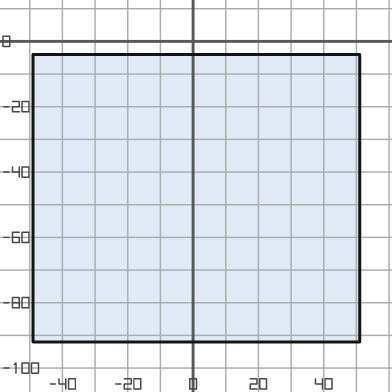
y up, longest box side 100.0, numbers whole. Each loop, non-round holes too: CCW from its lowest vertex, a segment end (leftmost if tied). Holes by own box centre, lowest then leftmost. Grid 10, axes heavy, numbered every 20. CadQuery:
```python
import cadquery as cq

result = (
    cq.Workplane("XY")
    .moveTo(-49.0, -92.0)
    .lineTo(51.0, -92.0)
    .lineTo(51.0, -4.0)
    .lineTo(-49.0, -4.0)
    .close()
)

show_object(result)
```